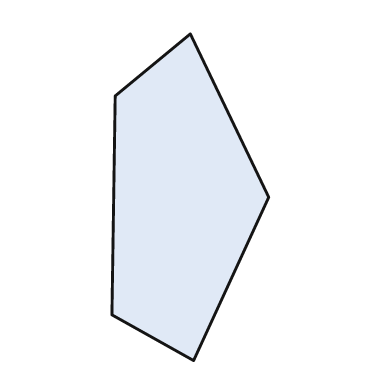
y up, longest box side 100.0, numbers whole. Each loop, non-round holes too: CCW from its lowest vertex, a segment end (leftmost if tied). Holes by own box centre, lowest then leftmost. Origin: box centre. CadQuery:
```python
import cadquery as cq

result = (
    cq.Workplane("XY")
    .moveTo(1.0, -50.0)
    .lineTo(24.0, 0.0)
    .lineTo(0.0, 50.0)
    .lineTo(-23.0, 31.0)
    .lineTo(-24.0, -36.0)
    .close()
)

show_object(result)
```